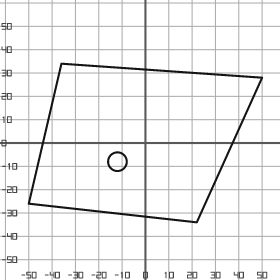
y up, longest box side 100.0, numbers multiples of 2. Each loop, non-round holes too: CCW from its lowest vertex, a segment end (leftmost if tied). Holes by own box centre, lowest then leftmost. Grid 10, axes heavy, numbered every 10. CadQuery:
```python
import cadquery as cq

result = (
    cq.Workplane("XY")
    .moveTo(22.0, -34.0)
    .lineTo(50.0, 28.0)
    .lineTo(-36.0, 34.0)
    .lineTo(-50.0, -26.0)
    .close()
    .moveTo(-12.0, -8.0)
    .circle(4.0)
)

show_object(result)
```